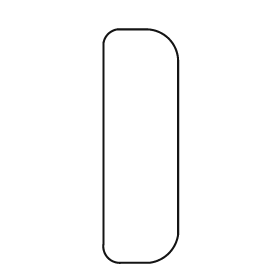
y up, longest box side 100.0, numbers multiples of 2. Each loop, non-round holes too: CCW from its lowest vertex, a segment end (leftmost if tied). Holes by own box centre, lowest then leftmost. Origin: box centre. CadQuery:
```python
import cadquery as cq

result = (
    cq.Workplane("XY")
    .moveTo(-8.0, -50.0)
    .lineTo(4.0, -50.0)
    .threePointArc((12.0, -46.0), (16.0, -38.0))
    .lineTo(16.0, 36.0)
    .threePointArc((12.0, 46.0), (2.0, 50.0))
    .lineTo(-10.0, 50.0)
    .threePointArc((-14.0, 48.0), (-16.0, 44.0))
    .lineTo(-16.0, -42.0)
    .threePointArc((-14.0, -48.0), (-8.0, -50.0))
    .close()
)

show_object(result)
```